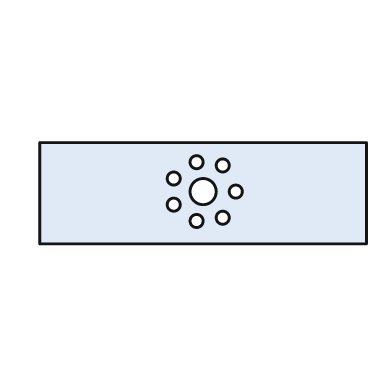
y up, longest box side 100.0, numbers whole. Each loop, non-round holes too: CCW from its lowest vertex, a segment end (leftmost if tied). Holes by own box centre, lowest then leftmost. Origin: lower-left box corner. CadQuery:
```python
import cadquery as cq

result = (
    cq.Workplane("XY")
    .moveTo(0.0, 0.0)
    .lineTo(100.0, 0.0)
    .lineTo(100.0, 31.0)
    .lineTo(0.0, 31.0)
    .close()
    .moveTo(48.0, 7.0)
    .circle(2.0)
    .moveTo(56.0, 8.0)
    .circle(2.0)
    .moveTo(41.0, 12.0)
    .circle(2.0)
    .moveTo(50.0, 16.0)
    .circle(4.0)
    .moveTo(60.0, 16.0)
    .circle(2.0)
    .moveTo(41.0, 20.0)
    .circle(2.0)
    .moveTo(56.0, 24.0)
    .circle(2.0)
    .moveTo(48.0, 25.0)
    .circle(2.0)
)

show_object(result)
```